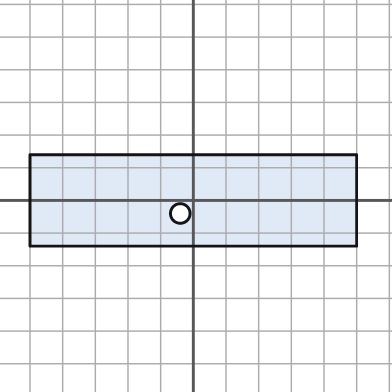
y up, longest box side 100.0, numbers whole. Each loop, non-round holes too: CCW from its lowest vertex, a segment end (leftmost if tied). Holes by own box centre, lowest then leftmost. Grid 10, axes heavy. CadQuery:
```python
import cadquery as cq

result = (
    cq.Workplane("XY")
    .moveTo(-50.0, -14.0)
    .lineTo(50.0, -14.0)
    .lineTo(50.0, 14.0)
    .lineTo(-50.0, 14.0)
    .close()
    .moveTo(-4.0, -4.0)
    .circle(3.0)
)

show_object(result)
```